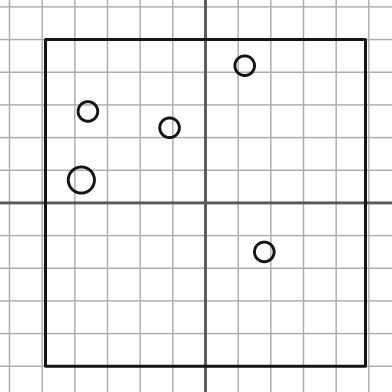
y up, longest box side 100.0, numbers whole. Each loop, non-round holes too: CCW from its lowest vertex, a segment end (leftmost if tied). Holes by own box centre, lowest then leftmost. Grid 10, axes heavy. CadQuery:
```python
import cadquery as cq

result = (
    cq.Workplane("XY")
    .moveTo(-49.0, -50.0)
    .lineTo(49.0, -50.0)
    .lineTo(49.0, 50.0)
    .lineTo(-49.0, 50.0)
    .close()
    .moveTo(18.0, -15.0)
    .circle(3.0)
    .moveTo(-38.0, 7.0)
    .circle(4.0)
    .moveTo(-11.0, 23.0)
    .circle(3.0)
    .moveTo(-36.0, 28.0)
    .circle(3.0)
    .moveTo(12.0, 42.0)
    .circle(3.0)
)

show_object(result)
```